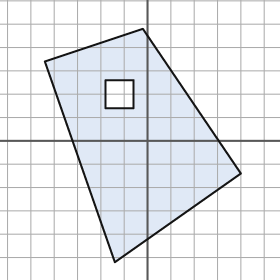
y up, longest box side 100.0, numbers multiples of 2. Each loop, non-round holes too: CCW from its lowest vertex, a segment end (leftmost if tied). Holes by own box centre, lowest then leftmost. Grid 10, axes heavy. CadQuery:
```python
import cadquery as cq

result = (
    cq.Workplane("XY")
    .moveTo(-14.0, -52.0)
    .lineTo(40.0, -14.0)
    .lineTo(-2.0, 48.0)
    .lineTo(-44.0, 34.0)
    .close()
    .moveTo(-18.0, 14.0)
    .lineTo(-6.0, 14.0)
    .lineTo(-6.0, 26.0)
    .lineTo(-18.0, 26.0)
    .close()
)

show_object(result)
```